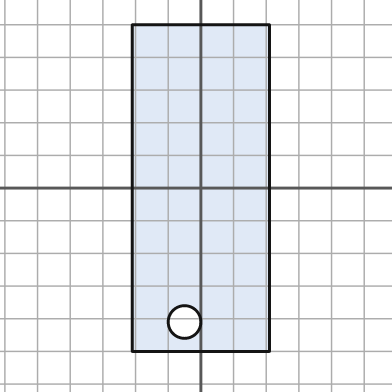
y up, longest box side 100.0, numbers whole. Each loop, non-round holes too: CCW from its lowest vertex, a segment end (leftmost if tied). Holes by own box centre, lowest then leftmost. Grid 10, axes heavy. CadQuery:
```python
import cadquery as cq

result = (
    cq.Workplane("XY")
    .moveTo(-21.0, -50.0)
    .lineTo(21.0, -50.0)
    .lineTo(21.0, 50.0)
    .lineTo(-21.0, 50.0)
    .close()
    .moveTo(-5.0, -41.0)
    .circle(5.0)
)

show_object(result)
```